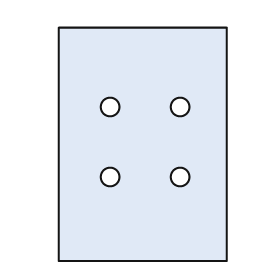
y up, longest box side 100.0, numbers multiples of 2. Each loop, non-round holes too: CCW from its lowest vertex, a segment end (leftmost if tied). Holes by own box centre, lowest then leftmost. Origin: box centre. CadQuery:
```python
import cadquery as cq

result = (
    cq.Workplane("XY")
    .moveTo(-36.0, -50.0)
    .lineTo(36.0, -50.0)
    .lineTo(36.0, 50.0)
    .lineTo(-36.0, 50.0)
    .close()
    .moveTo(-14.0, -14.0)
    .circle(4.0)
    .moveTo(16.0, -14.0)
    .circle(4.0)
    .moveTo(-14.0, 16.0)
    .circle(4.0)
    .moveTo(16.0, 16.0)
    .circle(4.0)
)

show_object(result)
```